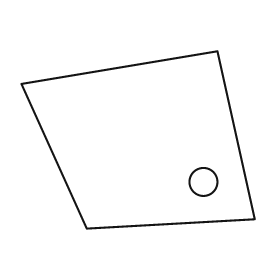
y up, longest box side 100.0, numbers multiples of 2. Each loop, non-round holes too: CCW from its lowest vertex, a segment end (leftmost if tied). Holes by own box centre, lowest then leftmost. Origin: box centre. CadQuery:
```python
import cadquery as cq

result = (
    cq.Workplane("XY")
    .moveTo(-22.0, -38.0)
    .lineTo(50.0, -34.0)
    .lineTo(34.0, 38.0)
    .lineTo(-50.0, 24.0)
    .close()
    .moveTo(28.0, -18.0)
    .circle(6.0)
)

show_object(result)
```